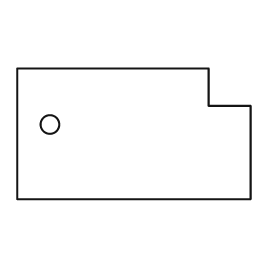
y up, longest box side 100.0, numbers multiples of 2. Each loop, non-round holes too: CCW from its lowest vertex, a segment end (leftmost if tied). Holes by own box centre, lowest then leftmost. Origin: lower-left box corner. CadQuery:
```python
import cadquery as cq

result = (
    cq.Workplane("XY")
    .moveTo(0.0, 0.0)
    .lineTo(100.0, 0.0)
    .lineTo(100.0, 40.0)
    .lineTo(82.0, 40.0)
    .lineTo(82.0, 56.0)
    .lineTo(0.0, 56.0)
    .close()
    .moveTo(14.0, 32.0)
    .circle(4.0)
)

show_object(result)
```